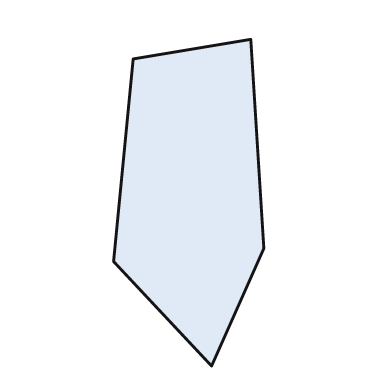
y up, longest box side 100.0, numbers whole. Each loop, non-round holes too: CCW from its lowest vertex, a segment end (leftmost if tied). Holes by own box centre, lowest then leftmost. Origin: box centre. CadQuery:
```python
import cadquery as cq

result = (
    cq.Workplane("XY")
    .moveTo(7.0, -50.0)
    .lineTo(23.0, -14.0)
    .lineTo(19.0, 50.0)
    .lineTo(-17.0, 44.0)
    .lineTo(-23.0, -18.0)
    .close()
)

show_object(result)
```